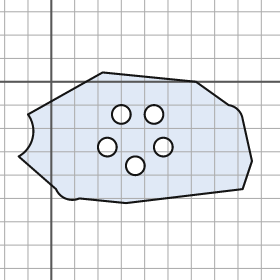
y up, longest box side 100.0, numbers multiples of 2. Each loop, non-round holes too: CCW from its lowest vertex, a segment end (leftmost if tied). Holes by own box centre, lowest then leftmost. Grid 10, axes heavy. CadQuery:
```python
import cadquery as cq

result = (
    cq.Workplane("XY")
    .moveTo(32.0, -52.0)
    .lineTo(82.0, -46.0)
    .lineTo(86.0, -34.0)
    .lineTo(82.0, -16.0)
    .threePointArc((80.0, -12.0), (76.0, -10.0))
    .lineTo(62.0, 0.0)
    .lineTo(22.0, 4.0)
    .lineTo(-10.0, -14.0)
    .threePointArc((-8.0, -24.0), (-14.0, -32.0))
    .lineTo(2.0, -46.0)
    .threePointArc((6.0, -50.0), (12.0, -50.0))
    .close()
    .moveTo(36.0, -36.0)
    .circle(4.0)
    .moveTo(24.0, -28.0)
    .circle(4.0)
    .moveTo(48.0, -28.0)
    .circle(4.0)
    .moveTo(30.0, -14.0)
    .circle(4.0)
    .moveTo(44.0, -14.0)
    .circle(4.0)
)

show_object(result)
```